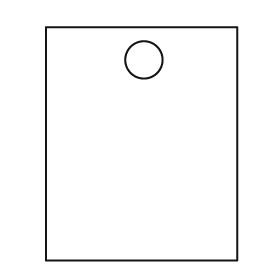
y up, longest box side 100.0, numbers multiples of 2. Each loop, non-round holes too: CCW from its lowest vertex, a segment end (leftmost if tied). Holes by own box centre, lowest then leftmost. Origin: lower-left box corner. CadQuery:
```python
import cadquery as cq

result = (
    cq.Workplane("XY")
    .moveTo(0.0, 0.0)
    .lineTo(82.0, 0.0)
    .lineTo(82.0, 100.0)
    .lineTo(0.0, 100.0)
    .close()
    .moveTo(42.0, 86.0)
    .circle(8.0)
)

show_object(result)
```